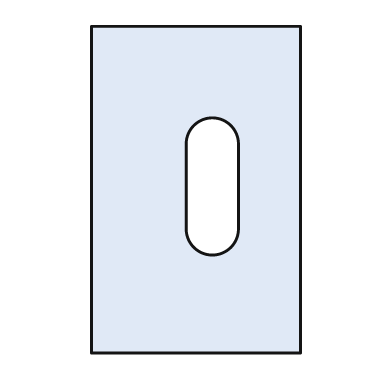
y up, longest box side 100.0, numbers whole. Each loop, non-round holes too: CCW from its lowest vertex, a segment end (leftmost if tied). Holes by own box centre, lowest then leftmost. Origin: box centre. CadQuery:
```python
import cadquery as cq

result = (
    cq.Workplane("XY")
    .moveTo(-32.0, -50.0)
    .lineTo(32.0, -50.0)
    .lineTo(32.0, 50.0)
    .lineTo(-32.0, 50.0)
    .close()
    .moveTo(-3.0, -12.0)
    .threePointArc((5.0, -20.0), (13.0, -12.0))
    .lineTo(13.0, 14.0)
    .threePointArc((5.0, 22.0), (-3.0, 14.0))
    .close()
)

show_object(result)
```